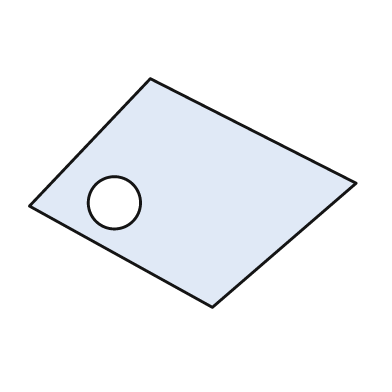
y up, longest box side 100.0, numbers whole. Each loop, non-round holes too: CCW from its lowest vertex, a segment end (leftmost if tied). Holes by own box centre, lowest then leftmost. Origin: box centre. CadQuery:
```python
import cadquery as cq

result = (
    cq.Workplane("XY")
    .moveTo(6.0, -35.0)
    .lineTo(50.0, 3.0)
    .lineTo(-13.0, 35.0)
    .lineTo(-50.0, -4.0)
    .close()
    .moveTo(-24.0, -3.0)
    .circle(8.0)
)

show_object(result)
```